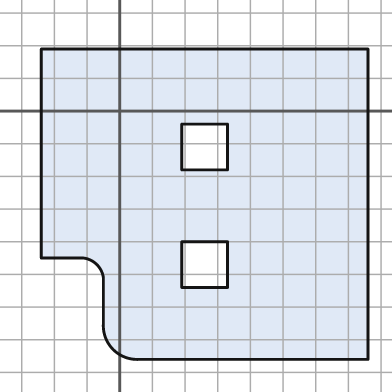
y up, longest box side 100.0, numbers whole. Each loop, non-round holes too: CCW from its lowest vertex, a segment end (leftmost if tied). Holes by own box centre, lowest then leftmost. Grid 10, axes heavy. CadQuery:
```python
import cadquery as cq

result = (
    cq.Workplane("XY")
    .moveTo(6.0, -76.0)
    .lineTo(76.0, -76.0)
    .lineTo(76.0, 19.0)
    .lineTo(-24.0, 19.0)
    .lineTo(-24.0, -45.0)
    .lineTo(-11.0, -45.0)
    .threePointArc((-7.0, -47.0), (-5.0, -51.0))
    .lineTo(-5.0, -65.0)
    .threePointArc((-2.0, -73.0), (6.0, -76.0))
    .close()
    .moveTo(19.0, -54.0)
    .lineTo(33.0, -54.0)
    .lineTo(33.0, -40.0)
    .lineTo(19.0, -40.0)
    .close()
    .moveTo(19.0, -18.0)
    .lineTo(33.0, -18.0)
    .lineTo(33.0, -4.0)
    .lineTo(19.0, -4.0)
    .close()
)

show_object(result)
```